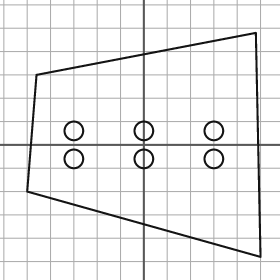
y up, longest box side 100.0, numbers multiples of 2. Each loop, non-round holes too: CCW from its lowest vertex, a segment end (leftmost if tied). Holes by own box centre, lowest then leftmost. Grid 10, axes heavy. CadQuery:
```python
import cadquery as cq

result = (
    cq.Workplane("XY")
    .moveTo(50.0, -48.0)
    .lineTo(48.0, 48.0)
    .lineTo(-46.0, 30.0)
    .lineTo(-50.0, -20.0)
    .close()
    .moveTo(-30.0, -6.0)
    .circle(4.0)
    .moveTo(0.0, -6.0)
    .circle(4.0)
    .moveTo(30.0, -6.0)
    .circle(4.0)
    .moveTo(-30.0, 6.0)
    .circle(4.0)
    .moveTo(0.0, 6.0)
    .circle(4.0)
    .moveTo(30.0, 6.0)
    .circle(4.0)
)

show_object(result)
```